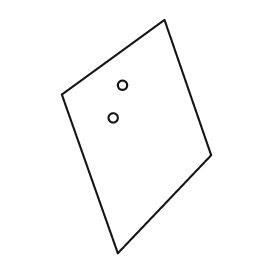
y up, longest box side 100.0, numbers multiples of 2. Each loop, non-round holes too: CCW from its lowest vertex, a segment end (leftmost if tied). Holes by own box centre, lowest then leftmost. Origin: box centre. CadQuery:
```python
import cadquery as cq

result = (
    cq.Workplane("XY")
    .moveTo(-8.0, -50.0)
    .lineTo(32.0, -8.0)
    .lineTo(12.0, 50.0)
    .lineTo(-32.0, 18.0)
    .close()
    .moveTo(-10.0, 8.0)
    .circle(2.0)
    .moveTo(-6.0, 22.0)
    .circle(2.0)
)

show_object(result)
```